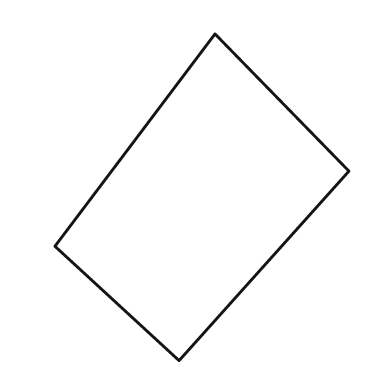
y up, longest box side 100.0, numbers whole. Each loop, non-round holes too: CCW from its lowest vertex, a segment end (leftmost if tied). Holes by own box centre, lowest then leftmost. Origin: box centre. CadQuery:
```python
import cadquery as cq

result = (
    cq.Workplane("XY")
    .moveTo(-7.0, -50.0)
    .lineTo(45.0, 8.0)
    .lineTo(4.0, 50.0)
    .lineTo(-45.0, -15.0)
    .close()
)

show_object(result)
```